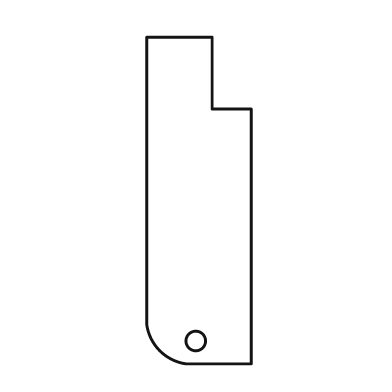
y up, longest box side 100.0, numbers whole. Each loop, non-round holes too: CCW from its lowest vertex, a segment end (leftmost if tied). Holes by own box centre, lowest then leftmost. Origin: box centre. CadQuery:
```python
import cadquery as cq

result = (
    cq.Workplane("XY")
    .moveTo(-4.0, -50.0)
    .lineTo(16.0, -50.0)
    .lineTo(16.0, 28.0)
    .lineTo(4.0, 28.0)
    .lineTo(4.0, 50.0)
    .lineTo(-16.0, 50.0)
    .lineTo(-16.0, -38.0)
    .threePointArc((-12.0, -46.0), (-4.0, -50.0))
    .close()
    .moveTo(-1.0, -43.0)
    .circle(3.0)
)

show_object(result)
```